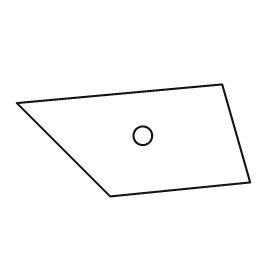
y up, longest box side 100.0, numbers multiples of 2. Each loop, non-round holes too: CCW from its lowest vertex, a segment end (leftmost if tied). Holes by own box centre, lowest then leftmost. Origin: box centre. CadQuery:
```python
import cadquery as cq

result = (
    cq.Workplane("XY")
    .moveTo(-10.0, -24.0)
    .lineTo(50.0, -18.0)
    .lineTo(38.0, 24.0)
    .lineTo(-50.0, 16.0)
    .close()
    .moveTo(4.0, 2.0)
    .circle(4.0)
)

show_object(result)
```